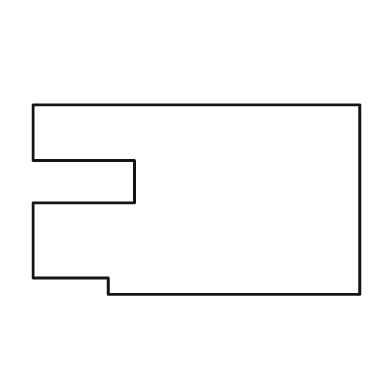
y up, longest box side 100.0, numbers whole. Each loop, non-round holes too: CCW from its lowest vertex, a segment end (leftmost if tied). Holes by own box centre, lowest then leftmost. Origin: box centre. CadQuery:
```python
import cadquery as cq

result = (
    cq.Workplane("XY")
    .moveTo(-27.0, -29.0)
    .lineTo(50.0, -29.0)
    .lineTo(50.0, 29.0)
    .lineTo(-50.0, 29.0)
    .lineTo(-50.0, 12.0)
    .lineTo(-19.0, 12.0)
    .lineTo(-19.0, -1.0)
    .lineTo(-50.0, -1.0)
    .lineTo(-50.0, -24.0)
    .lineTo(-27.0, -24.0)
    .close()
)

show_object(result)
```